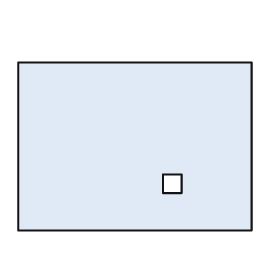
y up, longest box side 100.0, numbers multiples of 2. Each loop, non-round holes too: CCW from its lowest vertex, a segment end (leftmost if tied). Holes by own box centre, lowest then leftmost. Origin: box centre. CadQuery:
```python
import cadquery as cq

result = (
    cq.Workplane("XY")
    .moveTo(-50.0, -36.0)
    .lineTo(50.0, -36.0)
    .lineTo(50.0, 36.0)
    .lineTo(-50.0, 36.0)
    .close()
    .moveTo(12.0, -20.0)
    .lineTo(20.0, -20.0)
    .lineTo(20.0, -12.0)
    .lineTo(12.0, -12.0)
    .close()
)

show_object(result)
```